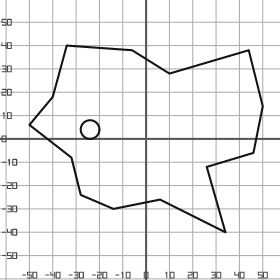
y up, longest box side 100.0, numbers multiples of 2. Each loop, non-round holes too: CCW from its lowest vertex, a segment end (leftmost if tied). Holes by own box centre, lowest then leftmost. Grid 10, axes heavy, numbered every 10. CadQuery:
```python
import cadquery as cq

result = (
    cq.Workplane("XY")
    .moveTo(34.0, -40.0)
    .lineTo(26.0, -12.0)
    .lineTo(46.0, -6.0)
    .lineTo(50.0, 14.0)
    .lineTo(44.0, 38.0)
    .lineTo(10.0, 28.0)
    .lineTo(-6.0, 38.0)
    .lineTo(-34.0, 40.0)
    .lineTo(-40.0, 18.0)
    .lineTo(-50.0, 6.0)
    .lineTo(-32.0, -8.0)
    .lineTo(-28.0, -24.0)
    .lineTo(-14.0, -30.0)
    .lineTo(6.0, -26.0)
    .close()
    .moveTo(-24.0, 4.0)
    .circle(4.0)
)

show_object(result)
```